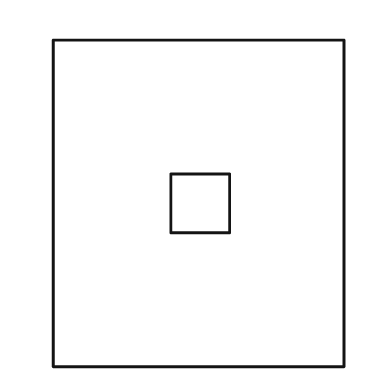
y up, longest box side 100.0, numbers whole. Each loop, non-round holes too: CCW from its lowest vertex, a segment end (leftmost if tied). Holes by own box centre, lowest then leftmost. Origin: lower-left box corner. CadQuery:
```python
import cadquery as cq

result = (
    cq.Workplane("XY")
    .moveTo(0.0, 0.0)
    .lineTo(89.0, 0.0)
    .lineTo(89.0, 100.0)
    .lineTo(0.0, 100.0)
    .close()
    .moveTo(36.0, 41.0)
    .lineTo(54.0, 41.0)
    .lineTo(54.0, 59.0)
    .lineTo(36.0, 59.0)
    .close()
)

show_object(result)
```